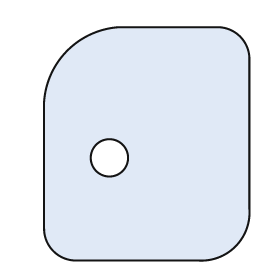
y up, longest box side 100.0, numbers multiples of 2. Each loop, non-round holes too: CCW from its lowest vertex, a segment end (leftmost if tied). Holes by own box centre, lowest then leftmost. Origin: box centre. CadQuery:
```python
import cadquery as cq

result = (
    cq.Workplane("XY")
    .moveTo(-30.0, -50.0)
    .lineTo(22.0, -50.0)
    .threePointArc((38.0, -44.0), (44.0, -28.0))
    .lineTo(44.0, 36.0)
    .threePointArc((40.0, 46.0), (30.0, 50.0))
    .lineTo(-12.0, 50.0)
    .threePointArc((-34.0, 40.0), (-44.0, 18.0))
    .lineTo(-44.0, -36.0)
    .threePointArc((-40.0, -46.0), (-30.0, -50.0))
    .close()
    .moveTo(-16.0, -6.0)
    .circle(8.0)
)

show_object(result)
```